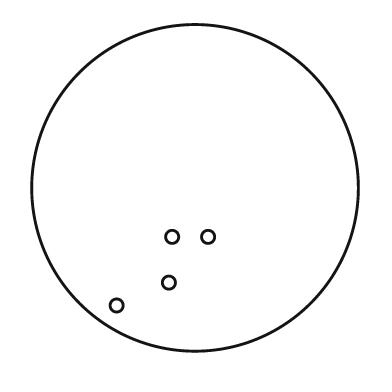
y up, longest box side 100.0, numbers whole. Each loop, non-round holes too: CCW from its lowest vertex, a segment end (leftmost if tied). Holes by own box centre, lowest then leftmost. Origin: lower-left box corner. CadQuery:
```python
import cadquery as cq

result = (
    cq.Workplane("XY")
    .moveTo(50.0, 50.0)
    .circle(50.0)
    .moveTo(26.0, 14.0)
    .circle(2.0)
    .moveTo(42.0, 21.0)
    .circle(2.0)
    .moveTo(43.0, 35.0)
    .circle(2.0)
    .moveTo(54.0, 35.0)
    .circle(2.0)
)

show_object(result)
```